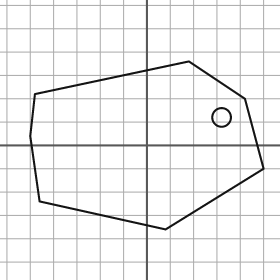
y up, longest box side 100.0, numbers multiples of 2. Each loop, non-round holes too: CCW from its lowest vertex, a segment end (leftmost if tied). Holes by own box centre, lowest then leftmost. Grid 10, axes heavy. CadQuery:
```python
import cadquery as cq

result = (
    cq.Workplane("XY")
    .moveTo(8.0, -36.0)
    .lineTo(50.0, -10.0)
    .lineTo(42.0, 20.0)
    .lineTo(18.0, 36.0)
    .lineTo(-48.0, 22.0)
    .lineTo(-50.0, 4.0)
    .lineTo(-46.0, -24.0)
    .close()
    .moveTo(32.0, 12.0)
    .circle(4.0)
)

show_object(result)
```